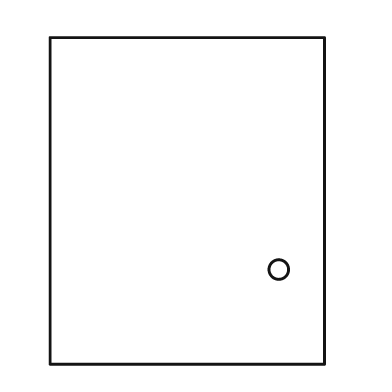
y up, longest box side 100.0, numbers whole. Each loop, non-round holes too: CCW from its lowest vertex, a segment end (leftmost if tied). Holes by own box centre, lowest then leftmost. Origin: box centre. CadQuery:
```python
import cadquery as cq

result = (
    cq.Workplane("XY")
    .moveTo(-42.0, -50.0)
    .lineTo(42.0, -50.0)
    .lineTo(42.0, 50.0)
    .lineTo(-42.0, 50.0)
    .close()
    .moveTo(28.0, -21.0)
    .circle(3.0)
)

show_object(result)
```